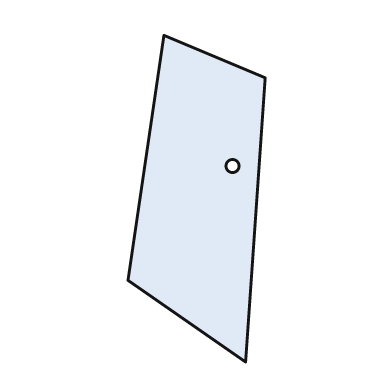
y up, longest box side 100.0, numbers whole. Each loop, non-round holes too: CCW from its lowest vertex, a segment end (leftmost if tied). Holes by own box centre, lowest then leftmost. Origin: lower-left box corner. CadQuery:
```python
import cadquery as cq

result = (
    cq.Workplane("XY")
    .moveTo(36.0, 0.0)
    .lineTo(42.0, 87.0)
    .lineTo(11.0, 100.0)
    .lineTo(0.0, 25.0)
    .close()
    .moveTo(32.0, 60.0)
    .circle(2.0)
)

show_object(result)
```